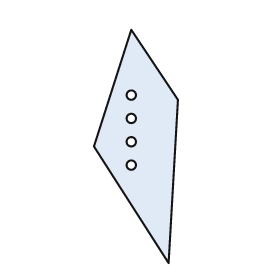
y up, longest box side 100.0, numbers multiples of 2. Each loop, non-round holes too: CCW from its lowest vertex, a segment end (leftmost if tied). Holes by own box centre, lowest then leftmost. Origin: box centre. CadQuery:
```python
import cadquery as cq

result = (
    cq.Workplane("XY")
    .moveTo(14.0, -50.0)
    .lineTo(18.0, 20.0)
    .lineTo(-2.0, 50.0)
    .lineTo(-18.0, 0.0)
    .close()
    .moveTo(-2.0, -8.0)
    .circle(2.0)
    .moveTo(-2.0, 2.0)
    .circle(2.0)
    .moveTo(-2.0, 12.0)
    .circle(2.0)
    .moveTo(-2.0, 22.0)
    .circle(2.0)
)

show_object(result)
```